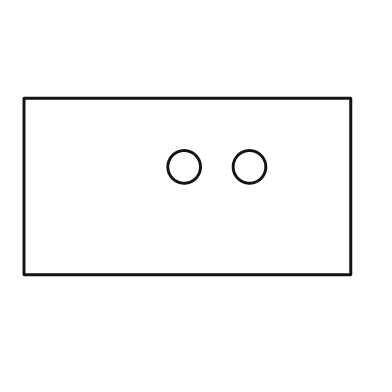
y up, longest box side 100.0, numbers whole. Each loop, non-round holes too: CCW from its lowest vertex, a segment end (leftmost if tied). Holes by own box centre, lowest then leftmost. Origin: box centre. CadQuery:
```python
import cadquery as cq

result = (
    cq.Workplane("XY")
    .moveTo(-50.0, -27.0)
    .lineTo(50.0, -27.0)
    .lineTo(50.0, 27.0)
    .lineTo(-50.0, 27.0)
    .close()
    .moveTo(-1.0, 6.0)
    .circle(5.0)
    .moveTo(19.0, 6.0)
    .circle(5.0)
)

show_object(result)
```